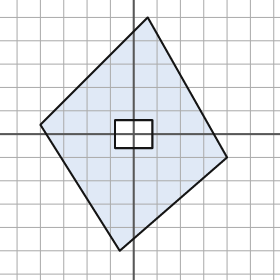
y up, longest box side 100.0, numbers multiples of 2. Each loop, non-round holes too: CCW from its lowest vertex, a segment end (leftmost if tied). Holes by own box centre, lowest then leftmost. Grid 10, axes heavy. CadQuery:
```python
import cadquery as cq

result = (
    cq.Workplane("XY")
    .moveTo(-6.0, -50.0)
    .lineTo(40.0, -10.0)
    .lineTo(6.0, 50.0)
    .lineTo(-40.0, 4.0)
    .close()
    .moveTo(-8.0, -6.0)
    .lineTo(8.0, -6.0)
    .lineTo(8.0, 6.0)
    .lineTo(-8.0, 6.0)
    .close()
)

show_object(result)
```